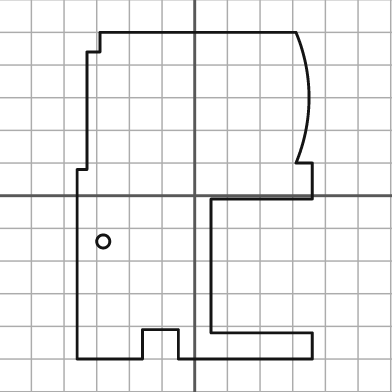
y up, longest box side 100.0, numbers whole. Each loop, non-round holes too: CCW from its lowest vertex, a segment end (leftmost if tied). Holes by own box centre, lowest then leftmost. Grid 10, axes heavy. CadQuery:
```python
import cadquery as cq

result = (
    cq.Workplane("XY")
    .moveTo(-36.0, -50.0)
    .lineTo(-16.0, -50.0)
    .lineTo(-16.0, -41.0)
    .lineTo(-5.0, -41.0)
    .lineTo(-5.0, -50.0)
    .lineTo(36.0, -50.0)
    .lineTo(36.0, -42.0)
    .lineTo(5.0, -42.0)
    .lineTo(5.0, -1.0)
    .lineTo(36.0, -1.0)
    .lineTo(36.0, 10.0)
    .lineTo(31.0, 10.0)
    .threePointArc((35.0, 30.0), (31.0, 50.0))
    .lineTo(-29.0, 50.0)
    .lineTo(-29.0, 44.0)
    .lineTo(-33.0, 44.0)
    .lineTo(-33.0, 8.0)
    .lineTo(-36.0, 8.0)
    .close()
    .moveTo(-28.0, -14.0)
    .circle(2.0)
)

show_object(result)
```